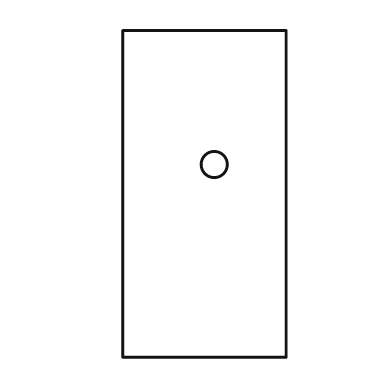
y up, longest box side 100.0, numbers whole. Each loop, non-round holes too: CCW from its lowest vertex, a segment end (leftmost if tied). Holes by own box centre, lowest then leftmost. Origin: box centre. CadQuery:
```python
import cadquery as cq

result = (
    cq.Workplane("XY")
    .moveTo(-25.0, -50.0)
    .lineTo(25.0, -50.0)
    .lineTo(25.0, 50.0)
    .lineTo(-25.0, 50.0)
    .close()
    .moveTo(3.0, 9.0)
    .circle(4.0)
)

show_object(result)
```